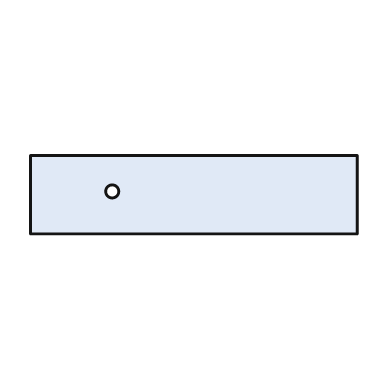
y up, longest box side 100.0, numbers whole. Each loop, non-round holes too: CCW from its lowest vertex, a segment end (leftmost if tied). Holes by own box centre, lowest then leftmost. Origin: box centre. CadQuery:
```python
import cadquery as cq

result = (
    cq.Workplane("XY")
    .moveTo(-50.0, -12.0)
    .lineTo(50.0, -12.0)
    .lineTo(50.0, 12.0)
    .lineTo(-50.0, 12.0)
    .close()
    .moveTo(-25.0, 1.0)
    .circle(2.0)
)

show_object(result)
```